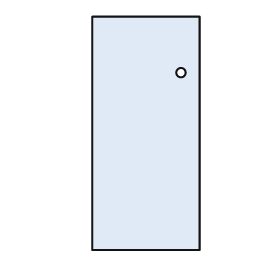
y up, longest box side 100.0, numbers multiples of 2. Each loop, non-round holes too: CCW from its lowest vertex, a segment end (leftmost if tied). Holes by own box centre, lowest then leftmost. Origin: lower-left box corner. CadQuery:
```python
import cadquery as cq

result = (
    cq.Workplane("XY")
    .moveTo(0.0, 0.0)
    .lineTo(46.0, 0.0)
    .lineTo(46.0, 100.0)
    .lineTo(0.0, 100.0)
    .close()
    .moveTo(38.0, 76.0)
    .circle(2.0)
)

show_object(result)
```